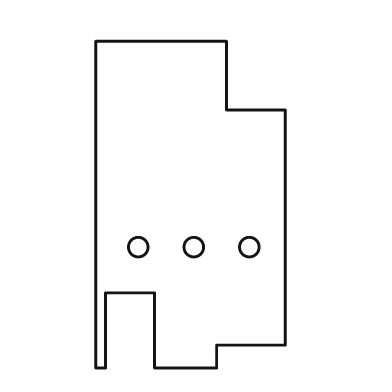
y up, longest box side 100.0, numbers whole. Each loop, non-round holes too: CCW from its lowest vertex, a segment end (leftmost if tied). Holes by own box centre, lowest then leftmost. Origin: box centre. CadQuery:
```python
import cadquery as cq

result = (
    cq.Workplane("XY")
    .moveTo(-29.0, -50.0)
    .lineTo(-26.0, -50.0)
    .lineTo(-26.0, -27.0)
    .lineTo(-11.0, -27.0)
    .lineTo(-11.0, -50.0)
    .lineTo(8.0, -50.0)
    .lineTo(8.0, -43.0)
    .lineTo(29.0, -43.0)
    .lineTo(29.0, 29.0)
    .lineTo(11.0, 29.0)
    .lineTo(11.0, 50.0)
    .lineTo(-29.0, 50.0)
    .close()
    .moveTo(-16.0, -13.0)
    .circle(3.0)
    .moveTo(1.0, -13.0)
    .circle(3.0)
    .moveTo(18.0, -13.0)
    .circle(3.0)
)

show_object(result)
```